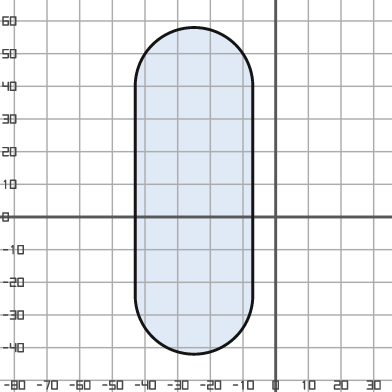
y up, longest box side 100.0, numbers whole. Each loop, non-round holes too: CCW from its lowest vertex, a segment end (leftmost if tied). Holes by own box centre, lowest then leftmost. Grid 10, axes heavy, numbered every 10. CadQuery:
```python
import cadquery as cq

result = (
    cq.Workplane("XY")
    .moveTo(-43.0, -24.0)
    .threePointArc((-25.0, -42.0), (-7.0, -24.0))
    .lineTo(-7.0, 40.0)
    .threePointArc((-25.0, 58.0), (-43.0, 40.0))
    .close()
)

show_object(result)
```